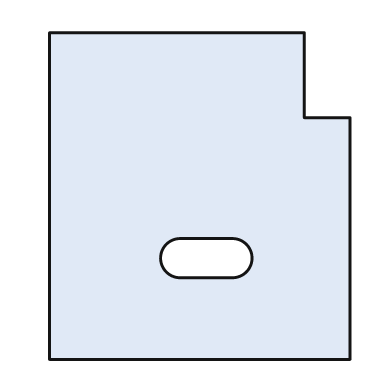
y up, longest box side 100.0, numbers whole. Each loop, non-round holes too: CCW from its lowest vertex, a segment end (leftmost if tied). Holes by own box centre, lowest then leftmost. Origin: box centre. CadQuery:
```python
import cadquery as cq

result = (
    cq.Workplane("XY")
    .moveTo(-46.0, -50.0)
    .lineTo(46.0, -50.0)
    .lineTo(46.0, 24.0)
    .lineTo(32.0, 24.0)
    .lineTo(32.0, 50.0)
    .lineTo(-46.0, 50.0)
    .close()
    .moveTo(-6.0, -25.0)
    .lineTo(10.0, -25.0)
    .threePointArc((16.0, -19.0), (10.0, -13.0))
    .lineTo(-6.0, -13.0)
    .threePointArc((-12.0, -19.0), (-6.0, -25.0))
    .close()
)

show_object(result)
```